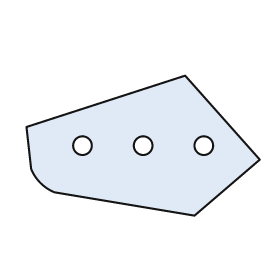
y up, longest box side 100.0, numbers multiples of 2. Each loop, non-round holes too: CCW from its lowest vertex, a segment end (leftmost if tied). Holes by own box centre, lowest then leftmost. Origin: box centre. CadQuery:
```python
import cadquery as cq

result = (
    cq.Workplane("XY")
    .moveTo(22.0, -30.0)
    .lineTo(50.0, -6.0)
    .lineTo(18.0, 30.0)
    .lineTo(-50.0, 8.0)
    .lineTo(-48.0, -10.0)
    .threePointArc((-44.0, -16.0), (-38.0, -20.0))
    .close()
    .moveTo(-26.0, 0.0)
    .circle(4.0)
    .moveTo(0.0, 0.0)
    .circle(4.0)
    .moveTo(26.0, 0.0)
    .circle(4.0)
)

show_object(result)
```